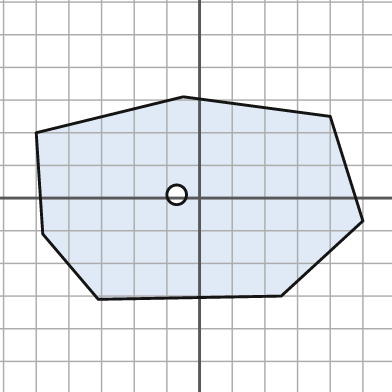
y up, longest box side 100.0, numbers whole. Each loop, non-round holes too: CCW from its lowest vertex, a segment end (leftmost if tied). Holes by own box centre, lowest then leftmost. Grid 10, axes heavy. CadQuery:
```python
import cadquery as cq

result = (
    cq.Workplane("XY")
    .moveTo(-31.0, -31.0)
    .lineTo(25.0, -30.0)
    .lineTo(50.0, -7.0)
    .lineTo(40.0, 25.0)
    .lineTo(-5.0, 31.0)
    .lineTo(-50.0, 20.0)
    .lineTo(-48.0, -11.0)
    .close()
    .moveTo(-7.0, 1.0)
    .circle(3.0)
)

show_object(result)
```